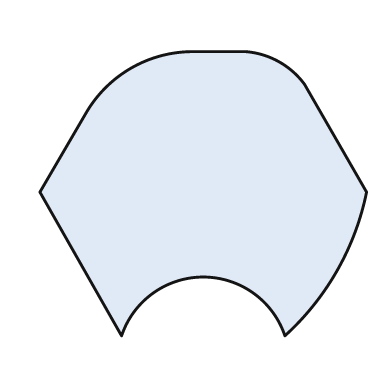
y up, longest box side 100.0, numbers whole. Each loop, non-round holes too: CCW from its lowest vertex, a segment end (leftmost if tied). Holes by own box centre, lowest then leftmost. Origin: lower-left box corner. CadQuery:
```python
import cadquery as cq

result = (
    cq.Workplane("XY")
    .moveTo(25.0, 0.0)
    .threePointArc((50.0, 18.0), (75.0, 0.0))
    .threePointArc((91.0, 20.0), (100.0, 44.0))
    .lineTo(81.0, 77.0)
    .threePointArc((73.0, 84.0), (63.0, 87.0))
    .lineTo(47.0, 87.0)
    .threePointArc((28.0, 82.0), (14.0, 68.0))
    .lineTo(0.0, 44.0)
    .close()
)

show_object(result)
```